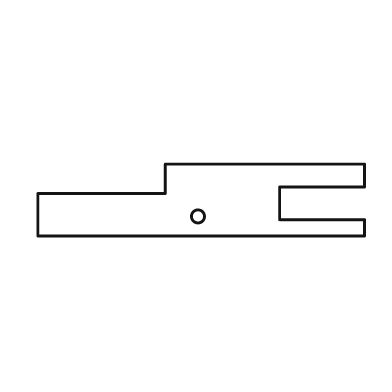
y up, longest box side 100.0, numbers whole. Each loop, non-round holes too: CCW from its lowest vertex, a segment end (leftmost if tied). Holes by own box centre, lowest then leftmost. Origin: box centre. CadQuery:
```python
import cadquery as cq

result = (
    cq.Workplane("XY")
    .moveTo(-50.0, -11.0)
    .lineTo(50.0, -11.0)
    .lineTo(50.0, -6.0)
    .lineTo(24.0, -6.0)
    .lineTo(24.0, 4.0)
    .lineTo(50.0, 4.0)
    .lineTo(50.0, 11.0)
    .lineTo(-11.0, 11.0)
    .lineTo(-11.0, 2.0)
    .lineTo(-50.0, 2.0)
    .close()
    .moveTo(-1.0, -5.0)
    .circle(2.0)
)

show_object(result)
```